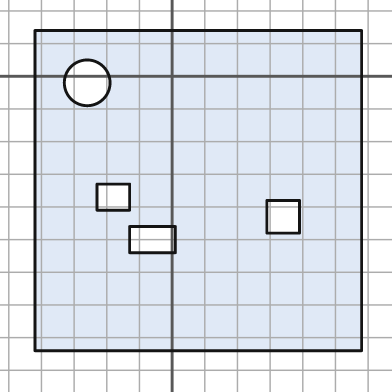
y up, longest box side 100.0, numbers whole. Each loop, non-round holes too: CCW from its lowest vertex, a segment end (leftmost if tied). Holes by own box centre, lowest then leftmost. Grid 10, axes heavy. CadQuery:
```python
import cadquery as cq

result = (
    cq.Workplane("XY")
    .moveTo(-42.0, -84.0)
    .lineTo(58.0, -84.0)
    .lineTo(58.0, 14.0)
    .lineTo(-42.0, 14.0)
    .close()
    .moveTo(-13.0, -54.0)
    .lineTo(1.0, -54.0)
    .lineTo(1.0, -46.0)
    .lineTo(-13.0, -46.0)
    .close()
    .moveTo(29.0, -48.0)
    .lineTo(39.0, -48.0)
    .lineTo(39.0, -38.0)
    .lineTo(29.0, -38.0)
    .close()
    .moveTo(-23.0, -41.0)
    .lineTo(-13.0, -41.0)
    .lineTo(-13.0, -33.0)
    .lineTo(-23.0, -33.0)
    .close()
    .moveTo(-26.0, -2.0)
    .circle(7.0)
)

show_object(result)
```